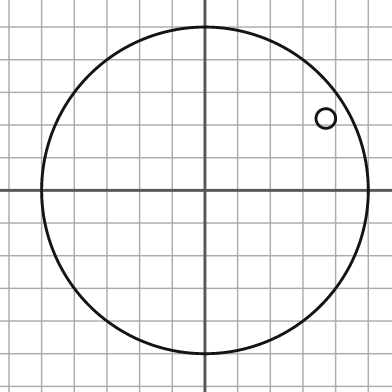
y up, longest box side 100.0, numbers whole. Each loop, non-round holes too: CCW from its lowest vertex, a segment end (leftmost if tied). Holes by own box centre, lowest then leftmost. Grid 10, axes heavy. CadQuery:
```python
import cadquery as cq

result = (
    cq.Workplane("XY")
    .moveTo(0.0, 0.0)
    .circle(50.0)
    .moveTo(37.0, 22.0)
    .circle(3.0)
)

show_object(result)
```